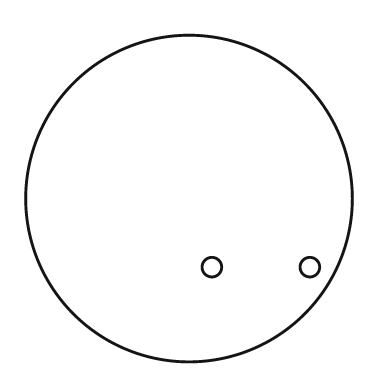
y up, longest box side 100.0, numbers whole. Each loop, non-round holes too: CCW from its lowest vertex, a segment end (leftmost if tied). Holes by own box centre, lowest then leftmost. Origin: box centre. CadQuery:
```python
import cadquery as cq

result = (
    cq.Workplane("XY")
    .moveTo(0.0, 0.0)
    .circle(50.0)
    .moveTo(7.0, -21.0)
    .circle(3.0)
    .moveTo(37.0, -21.0)
    .circle(3.0)
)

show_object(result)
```